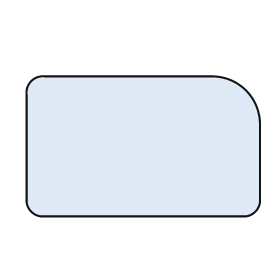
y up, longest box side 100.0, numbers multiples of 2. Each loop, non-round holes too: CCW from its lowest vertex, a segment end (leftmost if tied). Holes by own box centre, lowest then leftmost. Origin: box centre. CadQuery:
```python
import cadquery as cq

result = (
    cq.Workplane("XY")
    .moveTo(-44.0, -30.0)
    .lineTo(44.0, -30.0)
    .threePointArc((48.0, -28.0), (50.0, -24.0))
    .lineTo(50.0, 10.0)
    .threePointArc((44.0, 24.0), (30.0, 30.0))
    .lineTo(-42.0, 30.0)
    .threePointArc((-48.0, 28.0), (-50.0, 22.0))
    .lineTo(-50.0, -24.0)
    .threePointArc((-48.0, -28.0), (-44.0, -30.0))
    .close()
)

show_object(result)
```